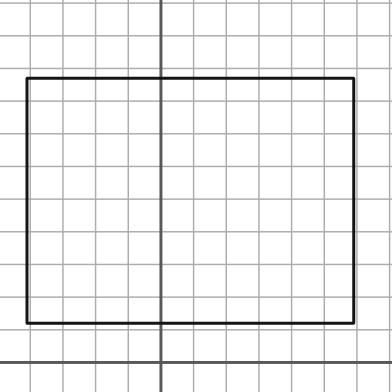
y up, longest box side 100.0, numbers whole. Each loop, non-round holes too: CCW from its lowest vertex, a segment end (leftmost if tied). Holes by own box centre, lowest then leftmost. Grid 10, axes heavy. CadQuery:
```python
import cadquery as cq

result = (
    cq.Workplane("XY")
    .moveTo(-41.0, 12.0)
    .lineTo(59.0, 12.0)
    .lineTo(59.0, 87.0)
    .lineTo(-41.0, 87.0)
    .close()
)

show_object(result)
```